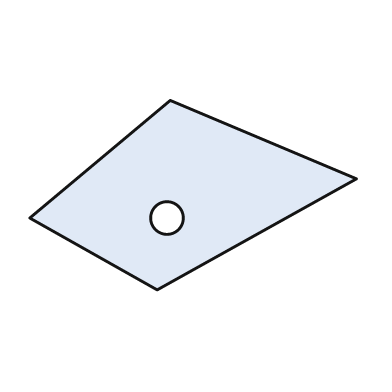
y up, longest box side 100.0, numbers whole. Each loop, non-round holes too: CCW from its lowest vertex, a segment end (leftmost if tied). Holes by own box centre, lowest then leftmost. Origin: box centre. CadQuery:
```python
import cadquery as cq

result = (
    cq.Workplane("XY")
    .moveTo(-11.0, -29.0)
    .lineTo(50.0, 5.0)
    .lineTo(-7.0, 29.0)
    .lineTo(-50.0, -7.0)
    .close()
    .moveTo(-8.0, -7.0)
    .circle(5.0)
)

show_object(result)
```